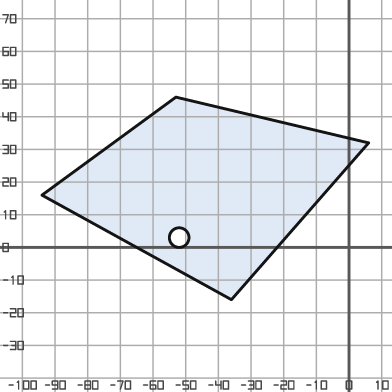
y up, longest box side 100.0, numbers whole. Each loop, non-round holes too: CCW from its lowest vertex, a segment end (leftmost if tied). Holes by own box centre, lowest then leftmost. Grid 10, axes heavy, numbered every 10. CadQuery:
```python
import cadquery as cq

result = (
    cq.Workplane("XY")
    .moveTo(-36.0, -16.0)
    .lineTo(6.0, 32.0)
    .lineTo(-53.0, 46.0)
    .lineTo(-94.0, 16.0)
    .close()
    .moveTo(-52.0, 3.0)
    .circle(3.0)
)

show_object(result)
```